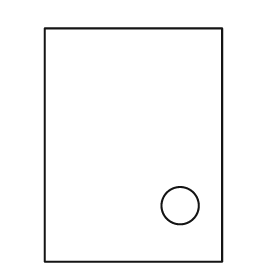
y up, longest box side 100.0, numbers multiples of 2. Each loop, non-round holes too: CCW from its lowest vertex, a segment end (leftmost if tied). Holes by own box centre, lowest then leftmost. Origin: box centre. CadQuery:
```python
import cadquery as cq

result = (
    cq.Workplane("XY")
    .moveTo(-38.0, -50.0)
    .lineTo(38.0, -50.0)
    .lineTo(38.0, 50.0)
    .lineTo(-38.0, 50.0)
    .close()
    .moveTo(20.0, -26.0)
    .circle(8.0)
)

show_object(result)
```